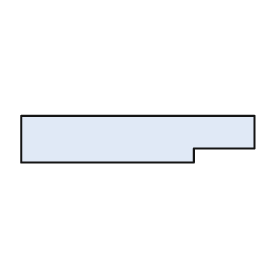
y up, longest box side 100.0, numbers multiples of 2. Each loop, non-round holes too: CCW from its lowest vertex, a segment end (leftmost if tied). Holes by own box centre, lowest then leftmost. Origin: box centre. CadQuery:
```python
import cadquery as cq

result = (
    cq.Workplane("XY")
    .moveTo(-50.0, -10.0)
    .lineTo(24.0, -10.0)
    .lineTo(24.0, -4.0)
    .lineTo(50.0, -4.0)
    .lineTo(50.0, 10.0)
    .lineTo(-50.0, 10.0)
    .close()
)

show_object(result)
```